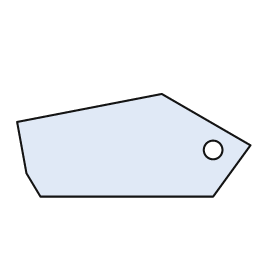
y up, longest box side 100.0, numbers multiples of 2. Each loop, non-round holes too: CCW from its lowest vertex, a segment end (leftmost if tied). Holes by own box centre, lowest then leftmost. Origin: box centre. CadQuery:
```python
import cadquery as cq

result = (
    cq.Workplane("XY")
    .moveTo(-40.0, -22.0)
    .lineTo(34.0, -22.0)
    .lineTo(50.0, 0.0)
    .lineTo(12.0, 22.0)
    .lineTo(-50.0, 10.0)
    .lineTo(-46.0, -12.0)
    .close()
    .moveTo(34.0, -2.0)
    .circle(4.0)
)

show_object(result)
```